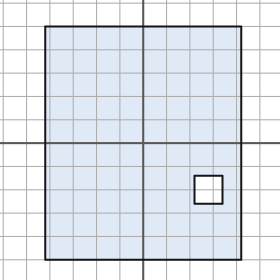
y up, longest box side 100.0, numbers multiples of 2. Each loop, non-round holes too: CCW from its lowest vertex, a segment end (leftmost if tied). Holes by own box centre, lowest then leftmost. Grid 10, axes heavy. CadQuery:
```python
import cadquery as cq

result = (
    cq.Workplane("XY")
    .moveTo(-42.0, -50.0)
    .lineTo(42.0, -50.0)
    .lineTo(42.0, 50.0)
    .lineTo(-42.0, 50.0)
    .close()
    .moveTo(22.0, -26.0)
    .lineTo(34.0, -26.0)
    .lineTo(34.0, -14.0)
    .lineTo(22.0, -14.0)
    .close()
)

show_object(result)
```